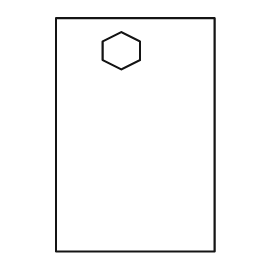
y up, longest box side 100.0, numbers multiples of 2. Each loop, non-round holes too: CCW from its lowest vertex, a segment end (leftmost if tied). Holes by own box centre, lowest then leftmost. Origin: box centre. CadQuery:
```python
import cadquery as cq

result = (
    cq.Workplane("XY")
    .moveTo(-34.0, -50.0)
    .lineTo(34.0, -50.0)
    .lineTo(34.0, 50.0)
    .lineTo(-34.0, 50.0)
    .close()
    .moveTo(-6.0, 28.0)
    .lineTo(2.0, 32.0)
    .lineTo(2.0, 40.0)
    .lineTo(-6.0, 44.0)
    .lineTo(-14.0, 40.0)
    .lineTo(-14.0, 32.0)
    .close()
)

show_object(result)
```